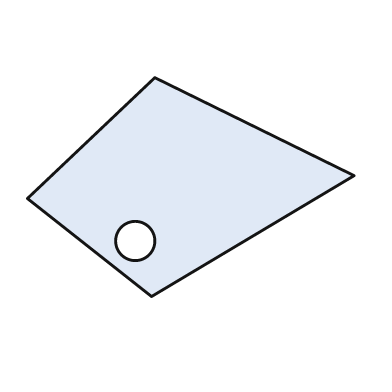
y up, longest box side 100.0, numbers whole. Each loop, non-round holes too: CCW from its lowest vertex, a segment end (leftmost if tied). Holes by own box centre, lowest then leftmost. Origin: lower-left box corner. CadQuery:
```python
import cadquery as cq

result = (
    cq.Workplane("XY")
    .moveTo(38.0, 0.0)
    .lineTo(100.0, 37.0)
    .lineTo(39.0, 67.0)
    .lineTo(0.0, 30.0)
    .close()
    .moveTo(33.0, 17.0)
    .circle(6.0)
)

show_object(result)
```